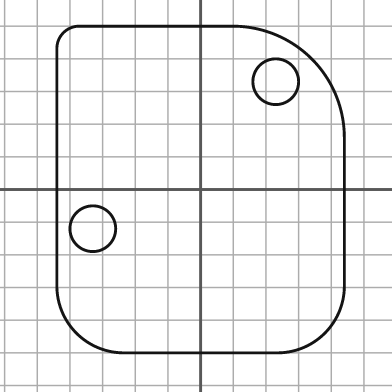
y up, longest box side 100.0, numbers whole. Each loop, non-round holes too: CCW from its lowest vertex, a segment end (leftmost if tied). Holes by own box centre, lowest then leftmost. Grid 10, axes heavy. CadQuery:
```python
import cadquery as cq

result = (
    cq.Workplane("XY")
    .moveTo(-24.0, -50.0)
    .lineTo(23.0, -50.0)
    .threePointArc((38.0, -44.0), (44.0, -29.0))
    .lineTo(44.0, 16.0)
    .threePointArc((34.0, 40.0), (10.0, 50.0))
    .lineTo(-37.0, 50.0)
    .threePointArc((-42.0, 48.0), (-44.0, 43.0))
    .lineTo(-44.0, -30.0)
    .threePointArc((-38.0, -44.0), (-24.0, -50.0))
    .close()
    .moveTo(-33.0, -12.0)
    .circle(7.0)
    .moveTo(23.0, 33.0)
    .circle(7.0)
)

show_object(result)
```